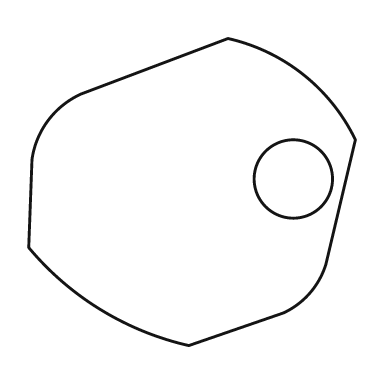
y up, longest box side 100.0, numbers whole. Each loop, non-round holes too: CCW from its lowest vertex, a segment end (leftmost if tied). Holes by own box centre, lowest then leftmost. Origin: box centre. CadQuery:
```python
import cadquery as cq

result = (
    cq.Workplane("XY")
    .moveTo(-1.0, -47.0)
    .lineTo(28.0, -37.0)
    .threePointArc((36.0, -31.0), (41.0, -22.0))
    .lineTo(50.0, 16.0)
    .threePointArc((34.0, 36.0), (11.0, 47.0))
    .lineTo(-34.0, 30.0)
    .threePointArc((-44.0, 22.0), (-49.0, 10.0))
    .lineTo(-50.0, -17.0)
    .threePointArc((-28.0, -36.0), (-1.0, -47.0))
    .close()
    .moveTo(31.0, 4.0)
    .circle(12.0)
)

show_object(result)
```